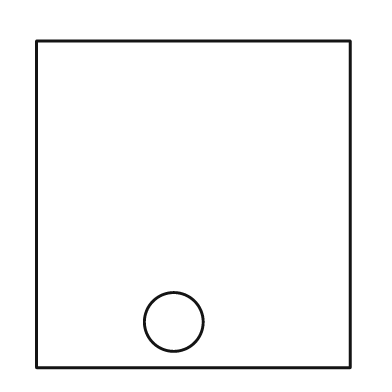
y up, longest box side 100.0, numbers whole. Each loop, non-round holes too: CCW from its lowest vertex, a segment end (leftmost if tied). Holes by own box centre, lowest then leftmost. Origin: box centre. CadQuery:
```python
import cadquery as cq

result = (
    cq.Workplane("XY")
    .moveTo(-48.0, -50.0)
    .lineTo(48.0, -50.0)
    .lineTo(48.0, 50.0)
    .lineTo(-48.0, 50.0)
    .close()
    .moveTo(-6.0, -36.0)
    .circle(9.0)
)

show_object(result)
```